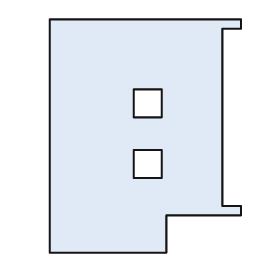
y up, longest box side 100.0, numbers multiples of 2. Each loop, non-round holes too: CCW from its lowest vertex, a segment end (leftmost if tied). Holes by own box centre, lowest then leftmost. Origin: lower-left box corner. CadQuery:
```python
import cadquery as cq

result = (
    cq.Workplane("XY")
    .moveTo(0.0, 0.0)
    .lineTo(50.0, 0.0)
    .lineTo(50.0, 16.0)
    .lineTo(82.0, 16.0)
    .lineTo(82.0, 20.0)
    .lineTo(74.0, 20.0)
    .lineTo(74.0, 96.0)
    .lineTo(82.0, 96.0)
    .lineTo(82.0, 100.0)
    .lineTo(0.0, 100.0)
    .close()
    .moveTo(36.0, 32.0)
    .lineTo(48.0, 32.0)
    .lineTo(48.0, 44.0)
    .lineTo(36.0, 44.0)
    .close()
    .moveTo(36.0, 58.0)
    .lineTo(48.0, 58.0)
    .lineTo(48.0, 70.0)
    .lineTo(36.0, 70.0)
    .close()
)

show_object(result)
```